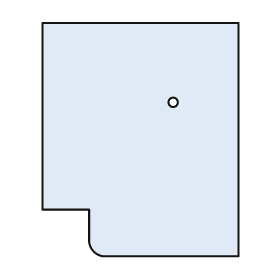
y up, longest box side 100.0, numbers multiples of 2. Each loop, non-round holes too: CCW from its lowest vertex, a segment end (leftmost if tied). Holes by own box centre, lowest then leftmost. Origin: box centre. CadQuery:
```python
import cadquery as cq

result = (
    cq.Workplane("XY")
    .moveTo(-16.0, -50.0)
    .lineTo(42.0, -50.0)
    .lineTo(42.0, 50.0)
    .lineTo(-42.0, 50.0)
    .lineTo(-42.0, -30.0)
    .lineTo(-22.0, -30.0)
    .lineTo(-22.0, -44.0)
    .threePointArc((-20.0, -48.0), (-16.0, -50.0))
    .close()
    .moveTo(14.0, 16.0)
    .circle(2.0)
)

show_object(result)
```